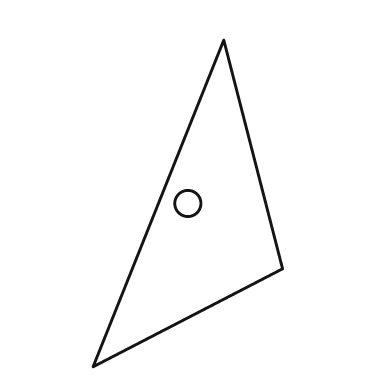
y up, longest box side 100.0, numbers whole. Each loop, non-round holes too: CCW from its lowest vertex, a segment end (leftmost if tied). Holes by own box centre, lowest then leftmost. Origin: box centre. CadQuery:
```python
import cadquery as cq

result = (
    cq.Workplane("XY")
    .moveTo(-29.0, -50.0)
    .lineTo(29.0, -20.0)
    .lineTo(11.0, 50.0)
    .close()
    .moveTo(0.0, 0.0)
    .circle(4.0)
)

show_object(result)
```